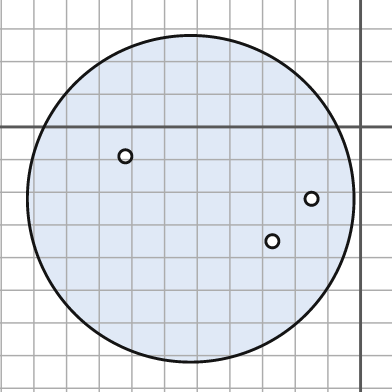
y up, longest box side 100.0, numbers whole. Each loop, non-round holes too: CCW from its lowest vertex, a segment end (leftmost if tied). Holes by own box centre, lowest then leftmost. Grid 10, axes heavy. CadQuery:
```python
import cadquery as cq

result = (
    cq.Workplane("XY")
    .moveTo(-52.0, -22.0)
    .circle(50.0)
    .moveTo(-27.0, -35.0)
    .circle(2.0)
    .moveTo(-15.0, -22.0)
    .circle(2.0)
    .moveTo(-72.0, -9.0)
    .circle(2.0)
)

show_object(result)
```